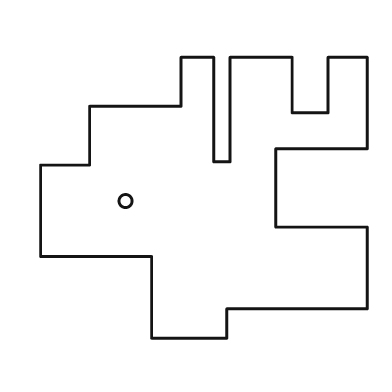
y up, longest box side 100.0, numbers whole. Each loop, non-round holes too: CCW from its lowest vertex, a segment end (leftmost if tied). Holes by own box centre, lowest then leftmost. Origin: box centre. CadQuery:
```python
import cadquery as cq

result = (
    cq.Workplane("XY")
    .moveTo(-16.0, -43.0)
    .lineTo(7.0, -43.0)
    .lineTo(7.0, -34.0)
    .lineTo(50.0, -34.0)
    .lineTo(50.0, -9.0)
    .lineTo(22.0, -9.0)
    .lineTo(22.0, 15.0)
    .lineTo(50.0, 15.0)
    .lineTo(50.0, 43.0)
    .lineTo(38.0, 43.0)
    .lineTo(38.0, 26.0)
    .lineTo(27.0, 26.0)
    .lineTo(27.0, 43.0)
    .lineTo(8.0, 43.0)
    .lineTo(8.0, 11.0)
    .lineTo(3.0, 11.0)
    .lineTo(3.0, 43.0)
    .lineTo(-7.0, 43.0)
    .lineTo(-7.0, 28.0)
    .lineTo(-35.0, 28.0)
    .lineTo(-35.0, 10.0)
    .lineTo(-50.0, 10.0)
    .lineTo(-50.0, -18.0)
    .lineTo(-16.0, -18.0)
    .close()
    .moveTo(-24.0, -1.0)
    .circle(2.0)
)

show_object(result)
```